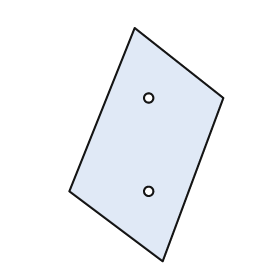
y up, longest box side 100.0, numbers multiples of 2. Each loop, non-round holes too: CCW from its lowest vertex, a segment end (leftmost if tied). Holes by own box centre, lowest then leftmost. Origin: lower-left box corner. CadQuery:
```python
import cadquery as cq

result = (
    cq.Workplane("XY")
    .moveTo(40.0, 0.0)
    .lineTo(66.0, 70.0)
    .lineTo(28.0, 100.0)
    .lineTo(0.0, 30.0)
    .close()
    .moveTo(34.0, 30.0)
    .circle(2.0)
    .moveTo(34.0, 70.0)
    .circle(2.0)
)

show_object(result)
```